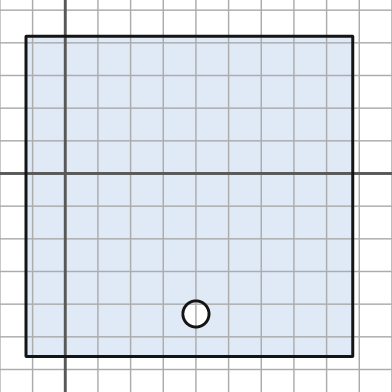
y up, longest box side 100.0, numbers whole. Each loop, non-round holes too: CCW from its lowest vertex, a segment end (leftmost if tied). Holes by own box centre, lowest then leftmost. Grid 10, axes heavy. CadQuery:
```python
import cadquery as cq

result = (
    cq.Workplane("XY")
    .moveTo(-12.0, -56.0)
    .lineTo(88.0, -56.0)
    .lineTo(88.0, 42.0)
    .lineTo(-12.0, 42.0)
    .close()
    .moveTo(40.0, -43.0)
    .circle(4.0)
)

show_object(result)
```